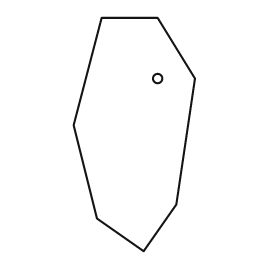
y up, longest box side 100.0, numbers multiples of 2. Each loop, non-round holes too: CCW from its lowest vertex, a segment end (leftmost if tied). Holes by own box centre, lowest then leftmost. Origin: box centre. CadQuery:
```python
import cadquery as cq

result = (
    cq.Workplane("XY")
    .moveTo(4.0, -50.0)
    .lineTo(18.0, -30.0)
    .lineTo(26.0, 24.0)
    .lineTo(10.0, 50.0)
    .lineTo(-14.0, 50.0)
    .lineTo(-26.0, 4.0)
    .lineTo(-16.0, -36.0)
    .close()
    .moveTo(10.0, 24.0)
    .circle(2.0)
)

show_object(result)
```